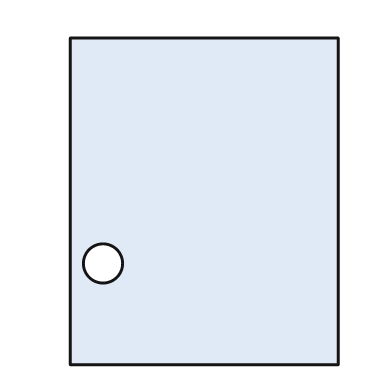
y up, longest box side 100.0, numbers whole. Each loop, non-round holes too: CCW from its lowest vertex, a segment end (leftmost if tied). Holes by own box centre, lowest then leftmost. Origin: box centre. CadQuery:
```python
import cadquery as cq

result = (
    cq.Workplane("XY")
    .moveTo(-41.0, -50.0)
    .lineTo(41.0, -50.0)
    .lineTo(41.0, 50.0)
    .lineTo(-41.0, 50.0)
    .close()
    .moveTo(-31.0, -19.0)
    .circle(6.0)
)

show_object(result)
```